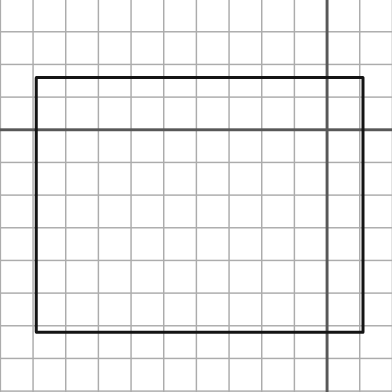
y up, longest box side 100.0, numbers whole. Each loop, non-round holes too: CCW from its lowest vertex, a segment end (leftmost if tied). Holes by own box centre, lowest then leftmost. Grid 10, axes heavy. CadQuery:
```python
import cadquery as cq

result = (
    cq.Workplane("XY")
    .moveTo(-89.0, -62.0)
    .lineTo(11.0, -62.0)
    .lineTo(11.0, 16.0)
    .lineTo(-89.0, 16.0)
    .close()
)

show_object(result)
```